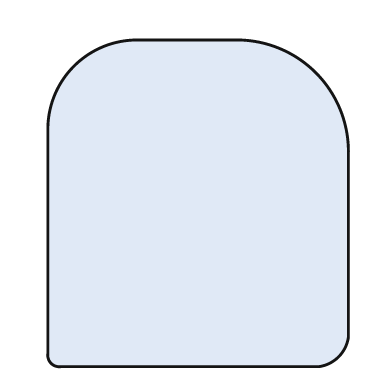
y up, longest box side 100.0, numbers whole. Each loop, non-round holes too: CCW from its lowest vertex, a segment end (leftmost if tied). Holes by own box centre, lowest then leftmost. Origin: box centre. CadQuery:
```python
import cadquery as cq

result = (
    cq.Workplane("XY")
    .moveTo(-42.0, -50.0)
    .lineTo(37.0, -50.0)
    .threePointArc((43.0, -47.0), (46.0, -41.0))
    .lineTo(46.0, 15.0)
    .threePointArc((36.0, 40.0), (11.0, 50.0))
    .lineTo(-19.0, 50.0)
    .threePointArc((-38.0, 42.0), (-46.0, 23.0))
    .lineTo(-46.0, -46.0)
    .threePointArc((-45.0, -49.0), (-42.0, -50.0))
    .close()
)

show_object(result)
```